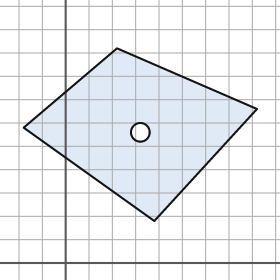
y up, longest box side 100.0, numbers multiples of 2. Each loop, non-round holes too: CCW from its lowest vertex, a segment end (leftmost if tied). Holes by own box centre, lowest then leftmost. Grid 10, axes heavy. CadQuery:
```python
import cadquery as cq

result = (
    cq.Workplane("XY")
    .moveTo(38.0, 18.0)
    .lineTo(82.0, 66.0)
    .lineTo(22.0, 92.0)
    .lineTo(-18.0, 58.0)
    .close()
    .moveTo(32.0, 56.0)
    .circle(4.0)
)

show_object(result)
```